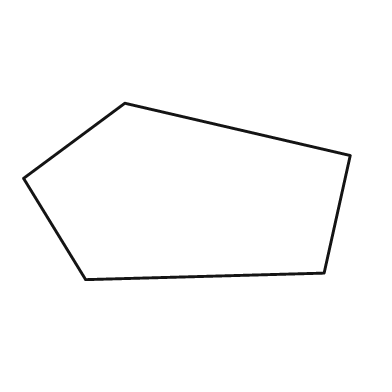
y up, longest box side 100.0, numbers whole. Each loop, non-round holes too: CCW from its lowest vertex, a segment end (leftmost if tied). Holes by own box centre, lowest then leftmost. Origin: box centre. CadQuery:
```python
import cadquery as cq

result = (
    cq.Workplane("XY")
    .moveTo(-31.0, -27.0)
    .lineTo(42.0, -25.0)
    .lineTo(50.0, 11.0)
    .lineTo(-19.0, 27.0)
    .lineTo(-50.0, 4.0)
    .close()
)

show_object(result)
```